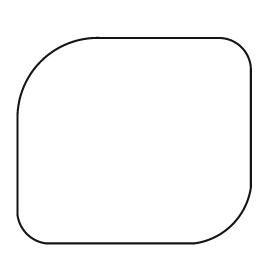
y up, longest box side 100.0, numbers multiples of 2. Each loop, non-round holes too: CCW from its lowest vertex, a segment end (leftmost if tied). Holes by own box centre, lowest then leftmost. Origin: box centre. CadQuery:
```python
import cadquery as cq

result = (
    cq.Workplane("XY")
    .moveTo(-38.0, -44.0)
    .lineTo(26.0, -44.0)
    .threePointArc((42.0, -36.0), (50.0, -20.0))
    .lineTo(50.0, 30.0)
    .threePointArc((46.0, 40.0), (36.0, 44.0))
    .lineTo(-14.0, 44.0)
    .threePointArc((-40.0, 34.0), (-50.0, 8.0))
    .lineTo(-50.0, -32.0)
    .threePointArc((-46.0, -40.0), (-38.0, -44.0))
    .close()
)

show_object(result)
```